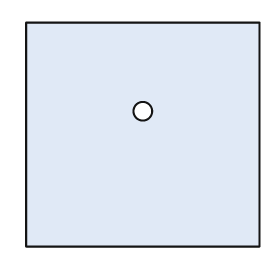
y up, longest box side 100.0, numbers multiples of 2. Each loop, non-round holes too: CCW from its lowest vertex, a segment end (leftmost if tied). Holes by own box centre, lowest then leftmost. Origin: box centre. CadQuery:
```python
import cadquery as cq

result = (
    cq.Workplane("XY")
    .moveTo(-50.0, -48.0)
    .lineTo(50.0, -48.0)
    .lineTo(50.0, 48.0)
    .lineTo(-50.0, 48.0)
    .close()
    .moveTo(0.0, 10.0)
    .circle(4.0)
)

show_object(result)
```